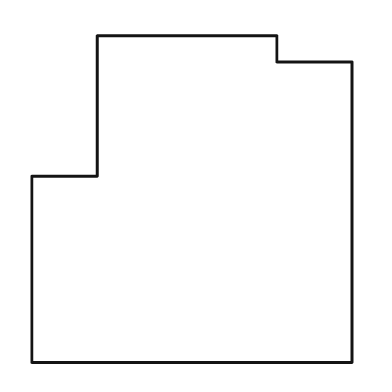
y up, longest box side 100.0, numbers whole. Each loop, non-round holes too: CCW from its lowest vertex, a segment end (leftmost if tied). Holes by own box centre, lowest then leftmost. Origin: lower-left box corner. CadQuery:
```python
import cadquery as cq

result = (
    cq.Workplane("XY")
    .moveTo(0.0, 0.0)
    .lineTo(98.0, 0.0)
    .lineTo(98.0, 92.0)
    .lineTo(75.0, 92.0)
    .lineTo(75.0, 100.0)
    .lineTo(20.0, 100.0)
    .lineTo(20.0, 57.0)
    .lineTo(0.0, 57.0)
    .close()
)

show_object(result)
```